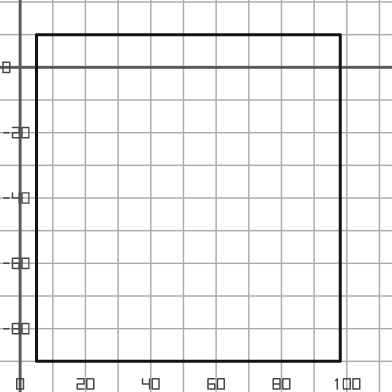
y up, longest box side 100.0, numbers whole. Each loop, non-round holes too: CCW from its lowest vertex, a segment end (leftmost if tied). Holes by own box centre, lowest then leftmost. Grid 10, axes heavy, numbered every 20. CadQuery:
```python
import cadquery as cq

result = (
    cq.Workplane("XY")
    .moveTo(5.0, -90.0)
    .lineTo(98.0, -90.0)
    .lineTo(98.0, 10.0)
    .lineTo(5.0, 10.0)
    .close()
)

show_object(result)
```